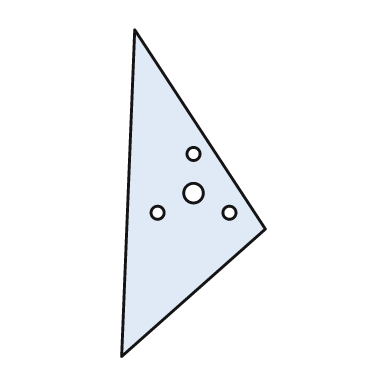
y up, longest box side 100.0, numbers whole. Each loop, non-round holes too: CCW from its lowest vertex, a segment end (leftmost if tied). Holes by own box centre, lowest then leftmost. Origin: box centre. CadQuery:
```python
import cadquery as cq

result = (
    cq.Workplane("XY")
    .moveTo(-22.0, -50.0)
    .lineTo(22.0, -11.0)
    .lineTo(-18.0, 50.0)
    .close()
    .moveTo(-11.0, -6.0)
    .circle(2.0)
    .moveTo(11.0, -6.0)
    .circle(2.0)
    .moveTo(0.0, 0.0)
    .circle(3.0)
    .moveTo(0.0, 12.0)
    .circle(2.0)
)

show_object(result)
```